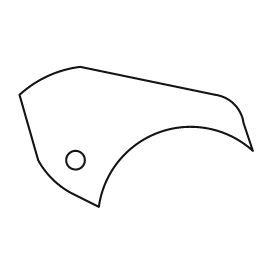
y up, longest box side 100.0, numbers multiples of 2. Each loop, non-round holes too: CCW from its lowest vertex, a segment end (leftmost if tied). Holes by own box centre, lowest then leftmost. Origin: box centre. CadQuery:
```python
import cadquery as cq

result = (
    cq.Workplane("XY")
    .moveTo(-16.0, -30.0)
    .threePointArc((10.0, 2.0), (50.0, -6.0))
    .lineTo(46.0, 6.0)
    .threePointArc((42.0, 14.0), (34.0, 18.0))
    .lineTo(-24.0, 30.0)
    .threePointArc((-38.0, 26.0), (-50.0, 18.0))
    .lineTo(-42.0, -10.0)
    .threePointArc((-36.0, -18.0), (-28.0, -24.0))
    .close()
    .moveTo(-26.0, -10.0)
    .circle(4.0)
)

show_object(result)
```